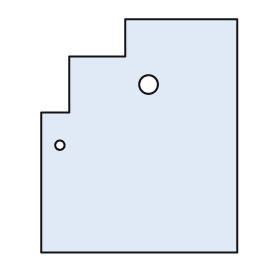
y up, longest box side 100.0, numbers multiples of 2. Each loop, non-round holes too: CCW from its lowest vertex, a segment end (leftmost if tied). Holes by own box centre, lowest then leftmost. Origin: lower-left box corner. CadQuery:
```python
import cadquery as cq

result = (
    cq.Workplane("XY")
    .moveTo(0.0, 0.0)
    .lineTo(84.0, 0.0)
    .lineTo(84.0, 100.0)
    .lineTo(36.0, 100.0)
    .lineTo(36.0, 84.0)
    .lineTo(12.0, 84.0)
    .lineTo(12.0, 60.0)
    .lineTo(0.0, 60.0)
    .close()
    .moveTo(8.0, 46.0)
    .circle(2.0)
    .moveTo(46.0, 72.0)
    .circle(4.0)
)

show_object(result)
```